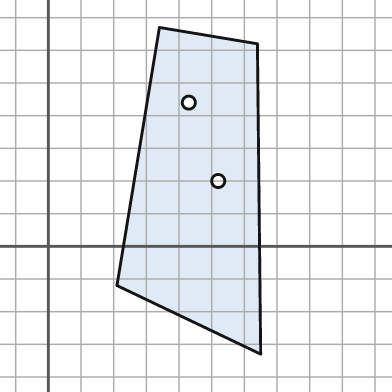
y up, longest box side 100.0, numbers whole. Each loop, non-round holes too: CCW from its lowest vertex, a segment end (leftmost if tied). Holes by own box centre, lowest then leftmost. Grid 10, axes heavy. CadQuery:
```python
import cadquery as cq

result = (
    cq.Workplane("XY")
    .moveTo(65.0, -33.0)
    .lineTo(64.0, 62.0)
    .lineTo(34.0, 67.0)
    .lineTo(21.0, -12.0)
    .close()
    .moveTo(52.0, 20.0)
    .circle(2.0)
    .moveTo(43.0, 44.0)
    .circle(2.0)
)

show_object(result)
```